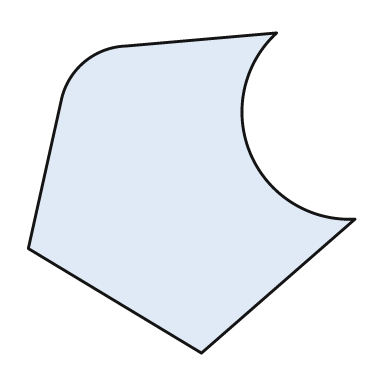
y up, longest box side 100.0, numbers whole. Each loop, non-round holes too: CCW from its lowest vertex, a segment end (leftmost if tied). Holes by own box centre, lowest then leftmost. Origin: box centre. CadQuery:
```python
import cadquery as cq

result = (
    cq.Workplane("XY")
    .moveTo(3.0, -49.0)
    .lineTo(50.0, -8.0)
    .threePointArc((18.0, 12.0), (26.0, 49.0))
    .lineTo(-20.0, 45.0)
    .threePointArc((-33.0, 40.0), (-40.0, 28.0))
    .lineTo(-50.0, -17.0)
    .close()
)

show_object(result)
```